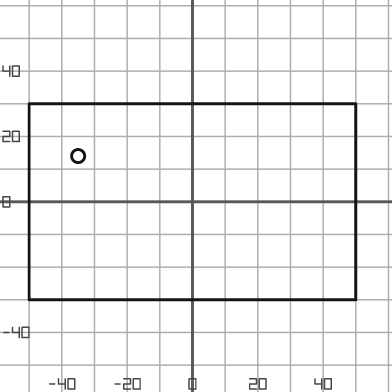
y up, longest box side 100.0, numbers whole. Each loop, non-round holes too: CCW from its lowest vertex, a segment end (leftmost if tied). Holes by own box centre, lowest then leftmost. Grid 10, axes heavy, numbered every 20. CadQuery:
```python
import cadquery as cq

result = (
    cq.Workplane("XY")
    .moveTo(-50.0, -30.0)
    .lineTo(50.0, -30.0)
    .lineTo(50.0, 30.0)
    .lineTo(-50.0, 30.0)
    .close()
    .moveTo(-35.0, 14.0)
    .circle(2.0)
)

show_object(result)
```